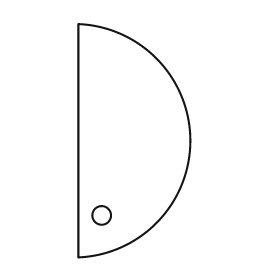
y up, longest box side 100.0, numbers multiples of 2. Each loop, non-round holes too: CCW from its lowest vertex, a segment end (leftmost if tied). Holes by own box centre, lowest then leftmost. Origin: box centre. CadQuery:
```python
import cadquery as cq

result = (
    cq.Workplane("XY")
    .moveTo(-24.0, -50.0)
    .threePointArc((24.0, 0.0), (-24.0, 50.0))
    .close()
    .moveTo(-14.0, -32.0)
    .circle(4.0)
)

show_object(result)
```